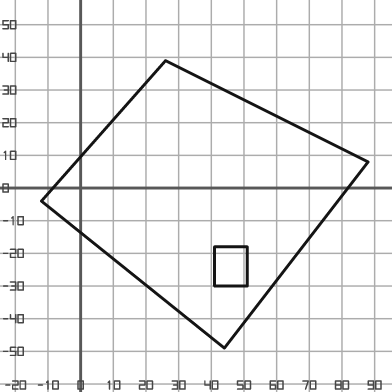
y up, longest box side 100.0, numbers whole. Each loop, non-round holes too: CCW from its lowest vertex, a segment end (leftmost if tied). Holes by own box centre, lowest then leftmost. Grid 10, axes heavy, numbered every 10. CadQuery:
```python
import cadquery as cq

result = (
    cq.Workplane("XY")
    .moveTo(44.0, -49.0)
    .lineTo(88.0, 8.0)
    .lineTo(26.0, 39.0)
    .lineTo(-12.0, -4.0)
    .close()
    .moveTo(41.0, -30.0)
    .lineTo(51.0, -30.0)
    .lineTo(51.0, -18.0)
    .lineTo(41.0, -18.0)
    .close()
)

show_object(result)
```